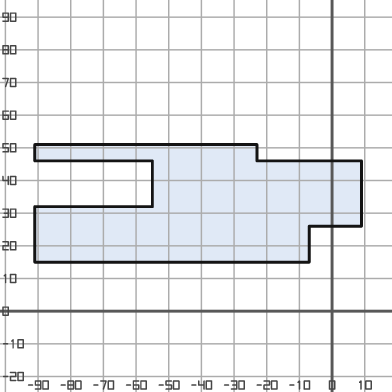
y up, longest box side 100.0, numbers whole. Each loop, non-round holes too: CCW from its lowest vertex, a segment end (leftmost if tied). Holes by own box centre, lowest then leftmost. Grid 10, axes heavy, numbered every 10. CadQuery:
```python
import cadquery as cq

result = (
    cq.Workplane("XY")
    .moveTo(-91.0, 15.0)
    .lineTo(-7.0, 15.0)
    .lineTo(-7.0, 26.0)
    .lineTo(9.0, 26.0)
    .lineTo(9.0, 46.0)
    .lineTo(-23.0, 46.0)
    .lineTo(-23.0, 51.0)
    .lineTo(-91.0, 51.0)
    .lineTo(-91.0, 46.0)
    .lineTo(-55.0, 46.0)
    .lineTo(-55.0, 32.0)
    .lineTo(-91.0, 32.0)
    .close()
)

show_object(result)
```